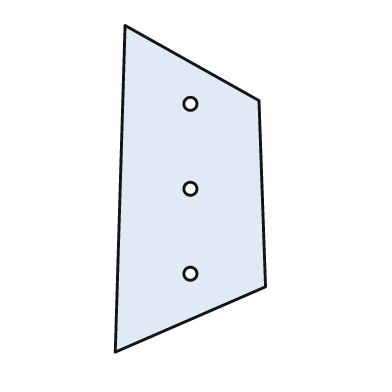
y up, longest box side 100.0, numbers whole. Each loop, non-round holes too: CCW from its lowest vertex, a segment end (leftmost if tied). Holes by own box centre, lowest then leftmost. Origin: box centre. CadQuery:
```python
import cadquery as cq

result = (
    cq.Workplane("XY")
    .moveTo(-23.0, -50.0)
    .lineTo(23.0, -30.0)
    .lineTo(21.0, 27.0)
    .lineTo(-20.0, 50.0)
    .close()
    .moveTo(0.0, -26.0)
    .circle(2.0)
    .moveTo(0.0, 0.0)
    .circle(2.0)
    .moveTo(0.0, 26.0)
    .circle(2.0)
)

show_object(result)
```